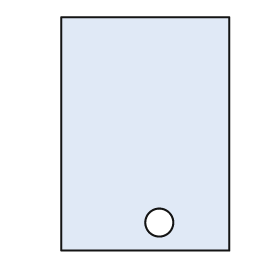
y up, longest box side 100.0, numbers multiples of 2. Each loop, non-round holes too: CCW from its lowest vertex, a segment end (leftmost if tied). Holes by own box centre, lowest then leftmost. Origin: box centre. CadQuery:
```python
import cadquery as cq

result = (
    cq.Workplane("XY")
    .moveTo(-36.0, -50.0)
    .lineTo(36.0, -50.0)
    .lineTo(36.0, 50.0)
    .lineTo(-36.0, 50.0)
    .close()
    .moveTo(6.0, -38.0)
    .circle(6.0)
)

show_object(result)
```